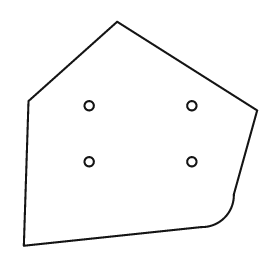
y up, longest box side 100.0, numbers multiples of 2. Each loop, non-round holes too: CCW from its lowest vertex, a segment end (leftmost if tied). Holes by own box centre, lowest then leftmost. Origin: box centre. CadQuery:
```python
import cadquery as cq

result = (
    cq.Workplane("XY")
    .moveTo(-50.0, -48.0)
    .lineTo(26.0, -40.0)
    .threePointArc((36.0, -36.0), (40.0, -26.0))
    .lineTo(50.0, 10.0)
    .lineTo(-10.0, 48.0)
    .lineTo(-48.0, 14.0)
    .close()
    .moveTo(-22.0, -12.0)
    .circle(2.0)
    .moveTo(22.0, -12.0)
    .circle(2.0)
    .moveTo(-22.0, 12.0)
    .circle(2.0)
    .moveTo(22.0, 12.0)
    .circle(2.0)
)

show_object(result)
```